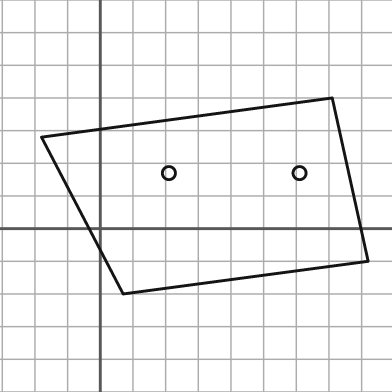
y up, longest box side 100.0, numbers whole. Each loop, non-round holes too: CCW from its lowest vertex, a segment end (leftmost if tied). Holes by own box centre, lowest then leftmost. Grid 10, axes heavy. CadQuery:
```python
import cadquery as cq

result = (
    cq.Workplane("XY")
    .moveTo(7.0, -20.0)
    .lineTo(82.0, -10.0)
    .lineTo(71.0, 40.0)
    .lineTo(-18.0, 28.0)
    .close()
    .moveTo(21.0, 17.0)
    .circle(2.0)
    .moveTo(61.0, 17.0)
    .circle(2.0)
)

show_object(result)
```